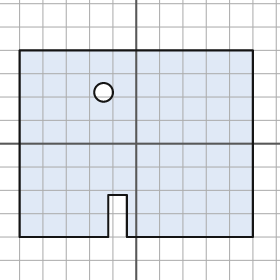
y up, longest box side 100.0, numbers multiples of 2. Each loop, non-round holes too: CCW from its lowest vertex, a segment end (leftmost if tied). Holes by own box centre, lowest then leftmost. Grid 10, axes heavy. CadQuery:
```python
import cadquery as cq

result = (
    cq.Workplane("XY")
    .moveTo(-50.0, -40.0)
    .lineTo(-12.0, -40.0)
    .lineTo(-12.0, -22.0)
    .lineTo(-4.0, -22.0)
    .lineTo(-4.0, -40.0)
    .lineTo(50.0, -40.0)
    .lineTo(50.0, 40.0)
    .lineTo(-50.0, 40.0)
    .close()
    .moveTo(-14.0, 22.0)
    .circle(4.0)
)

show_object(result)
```